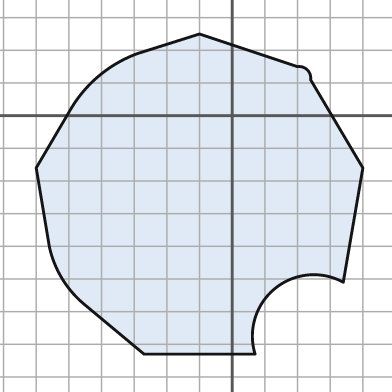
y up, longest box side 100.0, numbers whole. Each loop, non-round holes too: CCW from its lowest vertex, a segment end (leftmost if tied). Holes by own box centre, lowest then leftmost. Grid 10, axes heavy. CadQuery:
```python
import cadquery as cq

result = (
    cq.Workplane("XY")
    .moveTo(-27.0, -73.0)
    .lineTo(7.0, -73.0)
    .threePointArc((13.0, -53.0), (34.0, -51.0))
    .lineTo(40.0, -16.0)
    .lineTo(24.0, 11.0)
    .threePointArc((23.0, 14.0), (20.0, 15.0))
    .lineTo(-10.0, 25.0)
    .lineTo(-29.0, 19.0)
    .threePointArc((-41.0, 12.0), (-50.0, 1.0))
    .lineTo(-60.0, -16.0)
    .lineTo(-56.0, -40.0)
    .threePointArc((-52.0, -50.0), (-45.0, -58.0))
    .close()
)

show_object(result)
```